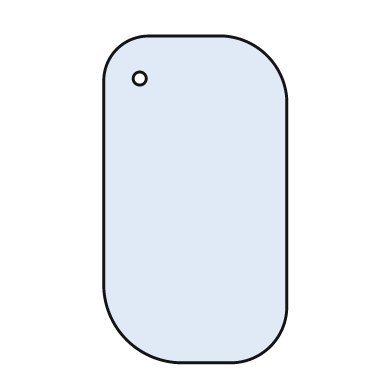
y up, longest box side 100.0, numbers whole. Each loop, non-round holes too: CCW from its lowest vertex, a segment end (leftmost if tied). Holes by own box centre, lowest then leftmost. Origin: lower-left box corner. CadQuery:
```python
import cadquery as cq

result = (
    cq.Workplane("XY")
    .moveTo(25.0, 0.0)
    .lineTo(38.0, 0.0)
    .threePointArc((51.0, 5.0), (56.0, 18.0))
    .lineTo(56.0, 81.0)
    .threePointArc((50.0, 94.0), (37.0, 100.0))
    .lineTo(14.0, 100.0)
    .threePointArc((4.0, 96.0), (0.0, 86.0))
    .lineTo(0.0, 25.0)
    .threePointArc((7.0, 7.0), (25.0, 0.0))
    .close()
    .moveTo(11.0, 87.0)
    .circle(2.0)
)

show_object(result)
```